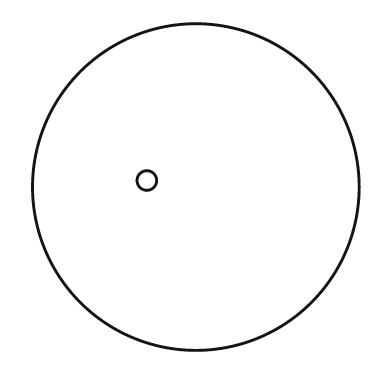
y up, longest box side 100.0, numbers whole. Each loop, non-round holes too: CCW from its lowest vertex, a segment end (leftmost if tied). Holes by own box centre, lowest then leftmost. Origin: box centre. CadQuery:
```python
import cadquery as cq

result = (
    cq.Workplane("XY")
    .moveTo(0.0, 0.0)
    .circle(50.0)
    .moveTo(-15.0, 2.0)
    .circle(3.0)
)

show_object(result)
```